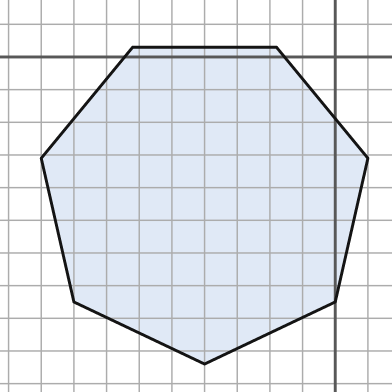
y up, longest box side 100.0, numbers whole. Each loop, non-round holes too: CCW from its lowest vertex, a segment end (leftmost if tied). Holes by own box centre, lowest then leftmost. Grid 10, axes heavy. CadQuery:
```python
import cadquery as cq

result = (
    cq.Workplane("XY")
    .moveTo(-40.0, -94.0)
    .lineTo(0.0, -75.0)
    .lineTo(10.0, -31.0)
    .lineTo(-18.0, 3.0)
    .lineTo(-62.0, 3.0)
    .lineTo(-90.0, -31.0)
    .lineTo(-80.0, -75.0)
    .close()
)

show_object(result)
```